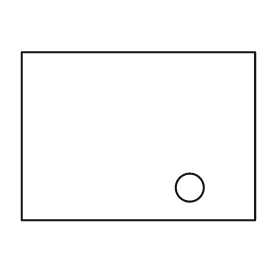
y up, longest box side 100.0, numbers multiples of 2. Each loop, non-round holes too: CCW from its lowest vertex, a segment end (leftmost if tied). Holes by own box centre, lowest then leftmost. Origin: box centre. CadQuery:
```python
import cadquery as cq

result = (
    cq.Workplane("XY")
    .moveTo(-50.0, -36.0)
    .lineTo(50.0, -36.0)
    .lineTo(50.0, 36.0)
    .lineTo(-50.0, 36.0)
    .close()
    .moveTo(22.0, -22.0)
    .circle(6.0)
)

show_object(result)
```